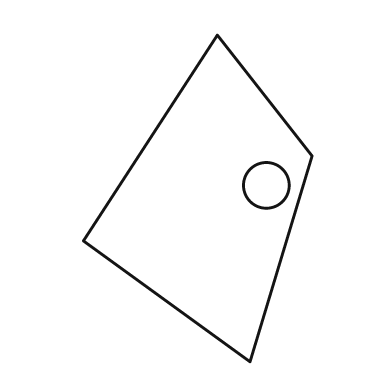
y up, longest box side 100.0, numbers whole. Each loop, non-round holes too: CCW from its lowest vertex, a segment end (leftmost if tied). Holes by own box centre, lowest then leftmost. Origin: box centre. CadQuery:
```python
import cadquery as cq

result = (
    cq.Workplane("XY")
    .moveTo(16.0, -50.0)
    .lineTo(35.0, 13.0)
    .lineTo(6.0, 50.0)
    .lineTo(-35.0, -13.0)
    .close()
    .moveTo(21.0, 4.0)
    .circle(7.0)
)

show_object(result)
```